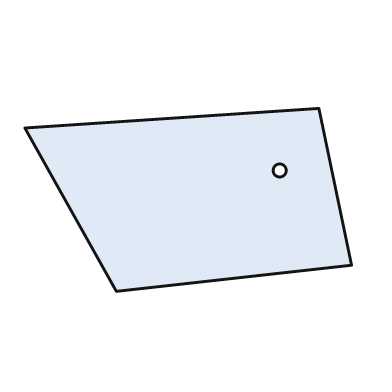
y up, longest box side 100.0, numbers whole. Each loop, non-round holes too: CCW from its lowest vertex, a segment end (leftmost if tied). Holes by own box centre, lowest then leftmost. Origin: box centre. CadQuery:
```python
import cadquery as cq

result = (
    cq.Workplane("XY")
    .moveTo(-22.0, -28.0)
    .lineTo(50.0, -20.0)
    .lineTo(40.0, 28.0)
    .lineTo(-50.0, 22.0)
    .close()
    .moveTo(28.0, 9.0)
    .circle(2.0)
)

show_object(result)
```